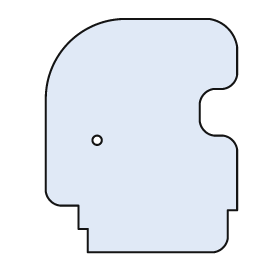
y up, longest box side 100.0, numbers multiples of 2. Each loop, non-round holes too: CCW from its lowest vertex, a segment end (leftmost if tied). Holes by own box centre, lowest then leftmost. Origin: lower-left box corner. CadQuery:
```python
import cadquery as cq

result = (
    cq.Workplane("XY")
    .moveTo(18.0, 0.0)
    .lineTo(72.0, 0.0)
    .threePointArc((76.0, 2.0), (78.0, 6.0))
    .lineTo(78.0, 18.0)
    .lineTo(82.0, 18.0)
    .lineTo(82.0, 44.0)
    .threePointArc((80.0, 48.0), (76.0, 50.0))
    .lineTo(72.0, 50.0)
    .threePointArc((68.0, 52.0), (66.0, 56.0))
    .lineTo(66.0, 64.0)
    .threePointArc((68.0, 68.0), (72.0, 70.0))
    .lineTo(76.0, 70.0)
    .threePointArc((80.0, 72.0), (82.0, 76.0))
    .lineTo(82.0, 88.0)
    .threePointArc((78.0, 96.0), (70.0, 100.0))
    .lineTo(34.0, 100.0)
    .threePointArc((10.0, 90.0), (0.0, 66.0))
    .lineTo(0.0, 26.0)
    .threePointArc((2.0, 22.0), (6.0, 20.0))
    .lineTo(14.0, 20.0)
    .lineTo(14.0, 10.0)
    .lineTo(18.0, 10.0)
    .close()
    .moveTo(22.0, 48.0)
    .circle(2.0)
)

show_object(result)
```